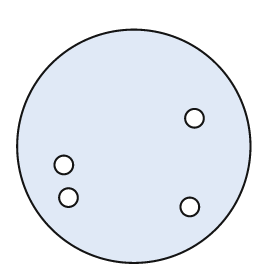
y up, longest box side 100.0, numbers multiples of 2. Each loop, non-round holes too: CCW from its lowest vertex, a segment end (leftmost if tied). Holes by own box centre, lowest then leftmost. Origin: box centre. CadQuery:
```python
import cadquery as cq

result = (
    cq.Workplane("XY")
    .moveTo(0.0, 0.0)
    .circle(50.0)
    .moveTo(24.0, -26.0)
    .circle(4.0)
    .moveTo(-28.0, -22.0)
    .circle(4.0)
    .moveTo(-30.0, -8.0)
    .circle(4.0)
    .moveTo(26.0, 12.0)
    .circle(4.0)
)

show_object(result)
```